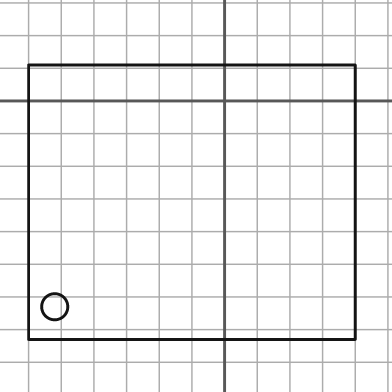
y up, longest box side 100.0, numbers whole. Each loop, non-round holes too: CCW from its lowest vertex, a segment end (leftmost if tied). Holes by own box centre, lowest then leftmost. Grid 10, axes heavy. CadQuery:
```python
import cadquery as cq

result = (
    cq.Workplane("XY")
    .moveTo(-60.0, -73.0)
    .lineTo(40.0, -73.0)
    .lineTo(40.0, 11.0)
    .lineTo(-60.0, 11.0)
    .close()
    .moveTo(-52.0, -63.0)
    .circle(4.0)
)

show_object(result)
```